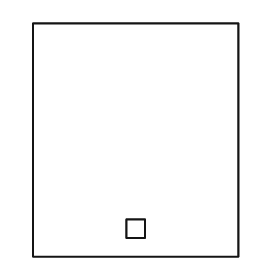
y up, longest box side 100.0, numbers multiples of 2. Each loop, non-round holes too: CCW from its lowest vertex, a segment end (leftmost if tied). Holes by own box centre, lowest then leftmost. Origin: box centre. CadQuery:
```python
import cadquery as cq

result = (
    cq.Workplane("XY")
    .moveTo(-44.0, -50.0)
    .lineTo(44.0, -50.0)
    .lineTo(44.0, 50.0)
    .lineTo(-44.0, 50.0)
    .close()
    .moveTo(-4.0, -42.0)
    .lineTo(4.0, -42.0)
    .lineTo(4.0, -34.0)
    .lineTo(-4.0, -34.0)
    .close()
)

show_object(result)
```